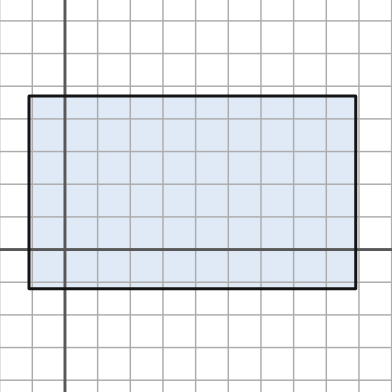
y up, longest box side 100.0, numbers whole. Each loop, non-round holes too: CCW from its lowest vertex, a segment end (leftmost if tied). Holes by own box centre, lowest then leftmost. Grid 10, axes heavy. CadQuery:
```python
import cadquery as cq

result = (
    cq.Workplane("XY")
    .moveTo(-11.0, -12.0)
    .lineTo(89.0, -12.0)
    .lineTo(89.0, 47.0)
    .lineTo(-11.0, 47.0)
    .close()
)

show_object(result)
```